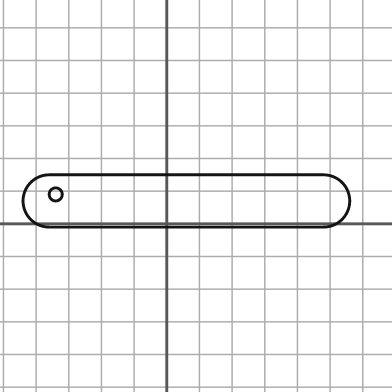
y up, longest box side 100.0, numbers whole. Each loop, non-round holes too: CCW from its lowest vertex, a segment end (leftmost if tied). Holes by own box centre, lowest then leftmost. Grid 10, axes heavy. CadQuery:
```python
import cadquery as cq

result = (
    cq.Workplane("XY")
    .moveTo(-36.0, -1.0)
    .lineTo(48.0, -1.0)
    .threePointArc((56.0, 7.0), (48.0, 15.0))
    .lineTo(-36.0, 15.0)
    .threePointArc((-44.0, 7.0), (-36.0, -1.0))
    .close()
    .moveTo(-34.0, 9.0)
    .circle(2.0)
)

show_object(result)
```